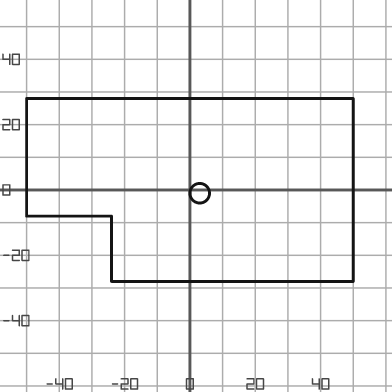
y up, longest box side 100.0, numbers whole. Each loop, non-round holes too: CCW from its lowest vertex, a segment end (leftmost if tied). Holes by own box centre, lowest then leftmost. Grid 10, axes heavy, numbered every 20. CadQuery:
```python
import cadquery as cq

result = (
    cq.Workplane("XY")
    .moveTo(-24.0, -28.0)
    .lineTo(50.0, -28.0)
    .lineTo(50.0, 28.0)
    .lineTo(-50.0, 28.0)
    .lineTo(-50.0, -8.0)
    .lineTo(-24.0, -8.0)
    .close()
    .moveTo(3.0, -1.0)
    .circle(3.0)
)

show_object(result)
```